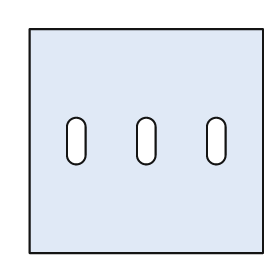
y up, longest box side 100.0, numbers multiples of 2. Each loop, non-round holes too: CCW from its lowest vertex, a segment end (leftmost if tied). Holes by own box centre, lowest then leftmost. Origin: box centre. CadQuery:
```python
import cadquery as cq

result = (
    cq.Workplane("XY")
    .moveTo(-50.0, -48.0)
    .lineTo(50.0, -48.0)
    .lineTo(50.0, 48.0)
    .lineTo(-50.0, 48.0)
    .close()
    .moveTo(-34.0, -6.0)
    .threePointArc((-30.0, -10.0), (-26.0, -6.0))
    .lineTo(-26.0, 6.0)
    .threePointArc((-30.0, 10.0), (-34.0, 6.0))
    .close()
    .moveTo(-4.0, -6.0)
    .threePointArc((0.0, -10.0), (4.0, -6.0))
    .lineTo(4.0, 6.0)
    .threePointArc((0.0, 10.0), (-4.0, 6.0))
    .close()
    .moveTo(26.0, -6.0)
    .threePointArc((30.0, -10.0), (34.0, -6.0))
    .lineTo(34.0, 6.0)
    .threePointArc((30.0, 10.0), (26.0, 6.0))
    .close()
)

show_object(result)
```